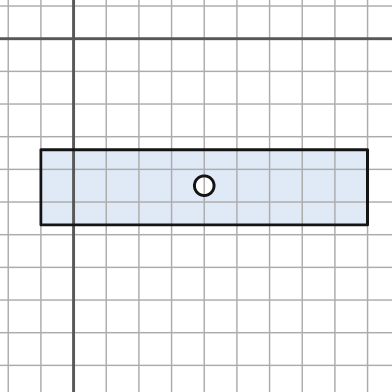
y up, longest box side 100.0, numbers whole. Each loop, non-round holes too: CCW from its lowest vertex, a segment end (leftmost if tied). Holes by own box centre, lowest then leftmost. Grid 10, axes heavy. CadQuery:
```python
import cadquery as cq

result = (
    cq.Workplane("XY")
    .moveTo(-10.0, -57.0)
    .lineTo(90.0, -57.0)
    .lineTo(90.0, -34.0)
    .lineTo(-10.0, -34.0)
    .close()
    .moveTo(40.0, -45.0)
    .circle(3.0)
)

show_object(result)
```